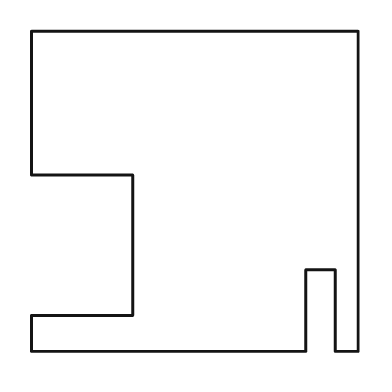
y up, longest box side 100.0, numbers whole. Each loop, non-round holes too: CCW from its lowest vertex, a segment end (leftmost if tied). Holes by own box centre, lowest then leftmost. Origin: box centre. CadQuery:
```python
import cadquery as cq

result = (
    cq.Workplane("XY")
    .moveTo(-50.0, -49.0)
    .lineTo(34.0, -49.0)
    .lineTo(34.0, -24.0)
    .lineTo(43.0, -24.0)
    .lineTo(43.0, -49.0)
    .lineTo(50.0, -49.0)
    .lineTo(50.0, 49.0)
    .lineTo(-50.0, 49.0)
    .lineTo(-50.0, 5.0)
    .lineTo(-19.0, 5.0)
    .lineTo(-19.0, -38.0)
    .lineTo(-50.0, -38.0)
    .close()
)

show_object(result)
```